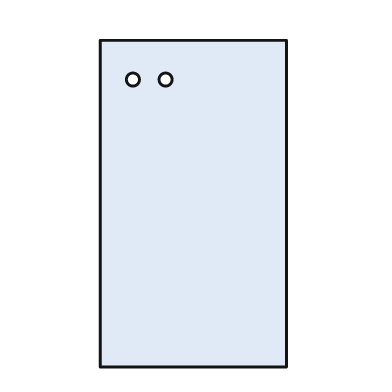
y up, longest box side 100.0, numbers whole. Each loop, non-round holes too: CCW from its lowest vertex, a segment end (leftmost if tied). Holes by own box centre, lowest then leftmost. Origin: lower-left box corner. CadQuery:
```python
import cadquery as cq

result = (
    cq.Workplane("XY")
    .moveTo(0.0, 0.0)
    .lineTo(57.0, 0.0)
    .lineTo(57.0, 100.0)
    .lineTo(0.0, 100.0)
    .close()
    .moveTo(10.0, 88.0)
    .circle(2.0)
    .moveTo(20.0, 88.0)
    .circle(2.0)
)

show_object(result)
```